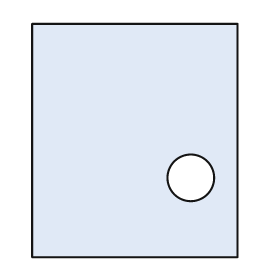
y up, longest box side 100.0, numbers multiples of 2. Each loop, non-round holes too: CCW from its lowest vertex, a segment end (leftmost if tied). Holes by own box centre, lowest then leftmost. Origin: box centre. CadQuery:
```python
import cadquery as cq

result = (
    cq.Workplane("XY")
    .moveTo(-44.0, -50.0)
    .lineTo(44.0, -50.0)
    .lineTo(44.0, 50.0)
    .lineTo(-44.0, 50.0)
    .close()
    .moveTo(24.0, -16.0)
    .circle(10.0)
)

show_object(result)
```